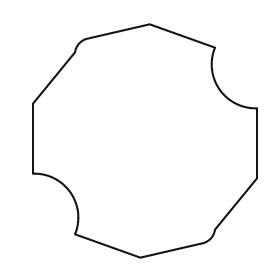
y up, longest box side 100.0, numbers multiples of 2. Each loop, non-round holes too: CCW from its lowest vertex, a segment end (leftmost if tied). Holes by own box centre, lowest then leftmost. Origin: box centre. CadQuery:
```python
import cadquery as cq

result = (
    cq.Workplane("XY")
    .moveTo(-2.0, -50.0)
    .lineTo(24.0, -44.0)
    .threePointArc((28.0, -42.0), (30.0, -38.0))
    .lineTo(48.0, -16.0)
    .lineTo(48.0, 14.0)
    .threePointArc((32.0, 22.0), (30.0, 40.0))
    .lineTo(2.0, 50.0)
    .lineTo(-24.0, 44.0)
    .threePointArc((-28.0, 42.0), (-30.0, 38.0))
    .lineTo(-48.0, 16.0)
    .lineTo(-48.0, -14.0)
    .threePointArc((-32.0, -22.0), (-30.0, -40.0))
    .close()
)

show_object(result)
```